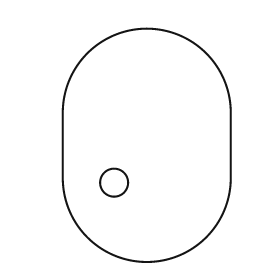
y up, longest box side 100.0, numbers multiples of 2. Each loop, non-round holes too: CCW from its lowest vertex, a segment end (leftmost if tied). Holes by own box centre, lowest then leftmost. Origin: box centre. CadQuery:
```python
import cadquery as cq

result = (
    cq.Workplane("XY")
    .moveTo(-36.0, -14.0)
    .threePointArc((0.0, -50.0), (36.0, -14.0))
    .lineTo(36.0, 14.0)
    .threePointArc((0.0, 50.0), (-36.0, 14.0))
    .close()
    .moveTo(-14.0, -16.0)
    .circle(6.0)
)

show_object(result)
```